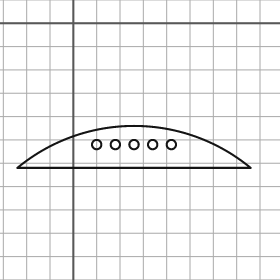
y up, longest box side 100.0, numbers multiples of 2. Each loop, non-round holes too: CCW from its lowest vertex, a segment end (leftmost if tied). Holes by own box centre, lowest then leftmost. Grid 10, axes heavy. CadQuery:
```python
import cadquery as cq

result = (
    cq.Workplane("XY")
    .moveTo(-24.0, -62.0)
    .lineTo(76.0, -62.0)
    .threePointArc((26.0, -44.0), (-24.0, -62.0))
    .close()
    .moveTo(10.0, -52.0)
    .circle(2.0)
    .moveTo(18.0, -52.0)
    .circle(2.0)
    .moveTo(26.0, -52.0)
    .circle(2.0)
    .moveTo(34.0, -52.0)
    .circle(2.0)
    .moveTo(42.0, -52.0)
    .circle(2.0)
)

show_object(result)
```